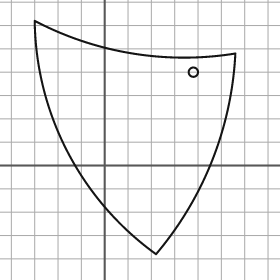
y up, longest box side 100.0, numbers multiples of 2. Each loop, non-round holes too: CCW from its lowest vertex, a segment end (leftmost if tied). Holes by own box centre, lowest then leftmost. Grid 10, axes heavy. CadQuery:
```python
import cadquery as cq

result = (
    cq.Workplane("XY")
    .moveTo(22.0, -38.0)
    .threePointArc((46.0, 2.0), (56.0, 48.0))
    .threePointArc((12.0, 48.0), (-30.0, 62.0))
    .threePointArc((-16.0, 6.0), (22.0, -38.0))
    .close()
    .moveTo(38.0, 40.0)
    .circle(2.0)
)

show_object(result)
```